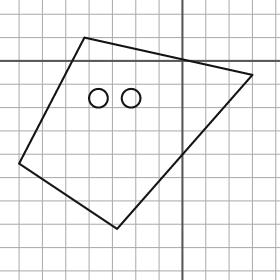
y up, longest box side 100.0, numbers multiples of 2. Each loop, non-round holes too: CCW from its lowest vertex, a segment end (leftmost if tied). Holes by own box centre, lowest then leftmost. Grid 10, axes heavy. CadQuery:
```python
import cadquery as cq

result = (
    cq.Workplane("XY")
    .moveTo(-28.0, -72.0)
    .lineTo(30.0, -6.0)
    .lineTo(-42.0, 10.0)
    .lineTo(-70.0, -44.0)
    .close()
    .moveTo(-36.0, -16.0)
    .circle(4.0)
    .moveTo(-22.0, -16.0)
    .circle(4.0)
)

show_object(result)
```